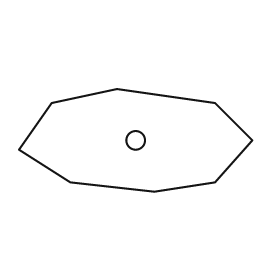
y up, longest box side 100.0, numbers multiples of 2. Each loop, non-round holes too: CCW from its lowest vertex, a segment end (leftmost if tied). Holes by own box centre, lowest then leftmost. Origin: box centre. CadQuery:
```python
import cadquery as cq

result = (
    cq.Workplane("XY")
    .moveTo(8.0, -22.0)
    .lineTo(34.0, -18.0)
    .lineTo(50.0, 0.0)
    .lineTo(34.0, 16.0)
    .lineTo(-8.0, 22.0)
    .lineTo(-36.0, 16.0)
    .lineTo(-50.0, -4.0)
    .lineTo(-28.0, -18.0)
    .close()
    .moveTo(0.0, 0.0)
    .circle(4.0)
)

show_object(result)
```